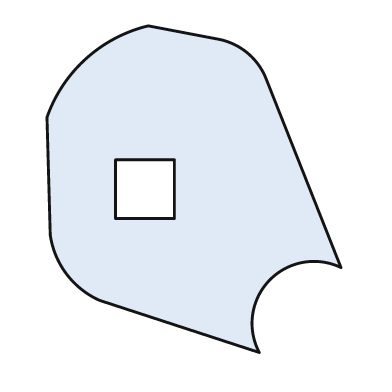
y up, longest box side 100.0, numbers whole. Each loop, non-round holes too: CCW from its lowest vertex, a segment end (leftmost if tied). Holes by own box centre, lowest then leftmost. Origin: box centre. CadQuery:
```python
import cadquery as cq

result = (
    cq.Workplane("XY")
    .moveTo(20.0, -50.0)
    .threePointArc((23.0, -28.0), (45.0, -24.0))
    .lineTo(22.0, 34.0)
    .threePointArc((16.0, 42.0), (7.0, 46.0))
    .lineTo(-14.0, 50.0)
    .threePointArc((-33.0, 40.0), (-45.0, 22.0))
    .lineTo(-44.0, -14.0)
    .threePointArc((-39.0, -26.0), (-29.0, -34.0))
    .close()
    .moveTo(-24.0, -9.0)
    .lineTo(-6.0, -9.0)
    .lineTo(-6.0, 9.0)
    .lineTo(-24.0, 9.0)
    .close()
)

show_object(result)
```